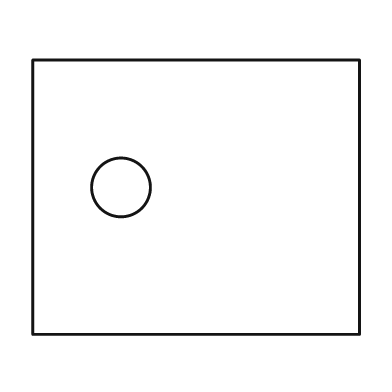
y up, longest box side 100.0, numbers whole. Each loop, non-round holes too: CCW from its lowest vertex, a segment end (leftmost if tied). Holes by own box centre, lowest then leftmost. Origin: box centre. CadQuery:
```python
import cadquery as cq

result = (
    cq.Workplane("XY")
    .moveTo(-50.0, -42.0)
    .lineTo(50.0, -42.0)
    .lineTo(50.0, 42.0)
    .lineTo(-50.0, 42.0)
    .close()
    .moveTo(-23.0, 3.0)
    .circle(9.0)
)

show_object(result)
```